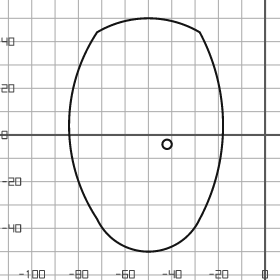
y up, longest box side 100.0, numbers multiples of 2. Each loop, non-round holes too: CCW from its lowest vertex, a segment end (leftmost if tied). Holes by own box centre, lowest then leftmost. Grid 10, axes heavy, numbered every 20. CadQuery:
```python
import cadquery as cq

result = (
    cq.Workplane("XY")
    .moveTo(-72.0, -36.0)
    .threePointArc((-50.0, -50.0), (-28.0, -36.0))
    .threePointArc((-18.0, 4.0), (-28.0, 44.0))
    .threePointArc((-50.0, 50.0), (-72.0, 44.0))
    .threePointArc((-84.0, 4.0), (-72.0, -36.0))
    .close()
    .moveTo(-42.0, -4.0)
    .circle(2.0)
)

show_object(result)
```